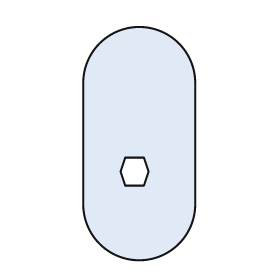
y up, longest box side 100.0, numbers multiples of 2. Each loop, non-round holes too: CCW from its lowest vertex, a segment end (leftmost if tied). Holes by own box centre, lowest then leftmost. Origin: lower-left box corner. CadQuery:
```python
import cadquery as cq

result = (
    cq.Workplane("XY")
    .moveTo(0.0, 24.0)
    .threePointArc((24.0, 0.0), (48.0, 24.0))
    .lineTo(48.0, 76.0)
    .threePointArc((24.0, 100.0), (0.0, 76.0))
    .close()
    .moveTo(18.0, 32.0)
    .lineTo(26.0, 32.0)
    .lineTo(28.0, 38.0)
    .lineTo(26.0, 44.0)
    .lineTo(18.0, 44.0)
    .lineTo(16.0, 38.0)
    .close()
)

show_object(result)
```